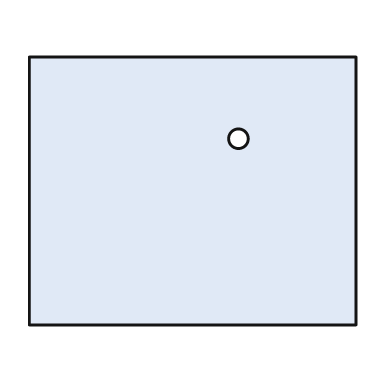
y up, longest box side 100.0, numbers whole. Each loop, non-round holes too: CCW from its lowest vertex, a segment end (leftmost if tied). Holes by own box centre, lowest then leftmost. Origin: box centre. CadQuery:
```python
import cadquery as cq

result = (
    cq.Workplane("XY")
    .moveTo(-50.0, -41.0)
    .lineTo(50.0, -41.0)
    .lineTo(50.0, 41.0)
    .lineTo(-50.0, 41.0)
    .close()
    .moveTo(14.0, 16.0)
    .circle(3.0)
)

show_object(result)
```